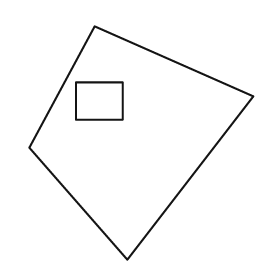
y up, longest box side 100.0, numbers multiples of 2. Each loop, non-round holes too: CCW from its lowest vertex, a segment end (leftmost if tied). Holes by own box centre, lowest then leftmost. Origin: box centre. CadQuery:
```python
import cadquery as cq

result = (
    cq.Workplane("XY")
    .moveTo(-6.0, -50.0)
    .lineTo(48.0, 20.0)
    .lineTo(-20.0, 50.0)
    .lineTo(-48.0, -2.0)
    .close()
    .moveTo(-28.0, 10.0)
    .lineTo(-8.0, 10.0)
    .lineTo(-8.0, 26.0)
    .lineTo(-28.0, 26.0)
    .close()
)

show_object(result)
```